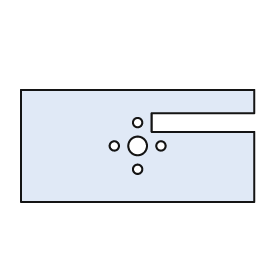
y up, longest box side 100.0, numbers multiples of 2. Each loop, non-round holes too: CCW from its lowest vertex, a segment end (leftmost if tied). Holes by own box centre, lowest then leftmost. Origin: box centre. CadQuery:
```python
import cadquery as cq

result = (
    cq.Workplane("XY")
    .moveTo(-50.0, -24.0)
    .lineTo(50.0, -24.0)
    .lineTo(50.0, 6.0)
    .lineTo(6.0, 6.0)
    .lineTo(6.0, 14.0)
    .lineTo(50.0, 14.0)
    .lineTo(50.0, 24.0)
    .lineTo(-50.0, 24.0)
    .close()
    .moveTo(0.0, -10.0)
    .circle(2.0)
    .moveTo(-10.0, 0.0)
    .circle(2.0)
    .moveTo(0.0, 0.0)
    .circle(4.0)
    .moveTo(10.0, 0.0)
    .circle(2.0)
    .moveTo(0.0, 10.0)
    .circle(2.0)
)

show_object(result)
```